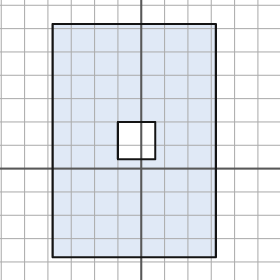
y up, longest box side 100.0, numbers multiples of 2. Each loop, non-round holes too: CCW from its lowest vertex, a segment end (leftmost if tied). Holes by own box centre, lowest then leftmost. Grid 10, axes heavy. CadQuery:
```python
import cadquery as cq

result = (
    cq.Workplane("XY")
    .moveTo(-38.0, -38.0)
    .lineTo(32.0, -38.0)
    .lineTo(32.0, 62.0)
    .lineTo(-38.0, 62.0)
    .close()
    .moveTo(-10.0, 4.0)
    .lineTo(6.0, 4.0)
    .lineTo(6.0, 20.0)
    .lineTo(-10.0, 20.0)
    .close()
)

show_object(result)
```